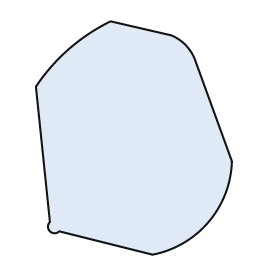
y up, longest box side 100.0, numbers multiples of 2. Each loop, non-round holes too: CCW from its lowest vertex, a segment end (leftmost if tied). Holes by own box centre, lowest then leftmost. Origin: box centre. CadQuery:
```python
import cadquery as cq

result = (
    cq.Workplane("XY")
    .moveTo(8.0, -50.0)
    .threePointArc((32.0, -36.0), (42.0, -10.0))
    .lineTo(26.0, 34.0)
    .threePointArc((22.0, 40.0), (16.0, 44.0))
    .lineTo(-10.0, 50.0)
    .threePointArc((-28.0, 38.0), (-42.0, 22.0))
    .lineTo(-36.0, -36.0)
    .threePointArc((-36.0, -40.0), (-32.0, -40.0))
    .close()
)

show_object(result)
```